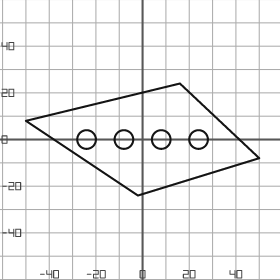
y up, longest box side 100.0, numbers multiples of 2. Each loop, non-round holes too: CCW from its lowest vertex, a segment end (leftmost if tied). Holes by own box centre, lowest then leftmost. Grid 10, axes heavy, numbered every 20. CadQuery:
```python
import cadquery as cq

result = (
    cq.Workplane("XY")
    .moveTo(-2.0, -24.0)
    .lineTo(50.0, -8.0)
    .lineTo(16.0, 24.0)
    .lineTo(-50.0, 8.0)
    .close()
    .moveTo(-24.0, 0.0)
    .circle(4.0)
    .moveTo(-8.0, 0.0)
    .circle(4.0)
    .moveTo(8.0, 0.0)
    .circle(4.0)
    .moveTo(24.0, 0.0)
    .circle(4.0)
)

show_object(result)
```